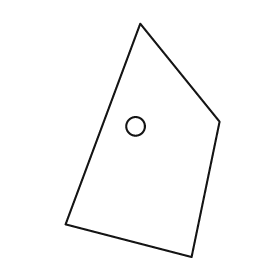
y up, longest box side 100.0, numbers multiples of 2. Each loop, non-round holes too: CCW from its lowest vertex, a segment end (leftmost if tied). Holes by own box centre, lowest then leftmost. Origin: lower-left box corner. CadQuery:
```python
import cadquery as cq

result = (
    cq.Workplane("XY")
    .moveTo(54.0, 0.0)
    .lineTo(66.0, 58.0)
    .lineTo(32.0, 100.0)
    .lineTo(0.0, 14.0)
    .close()
    .moveTo(30.0, 56.0)
    .circle(4.0)
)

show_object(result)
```